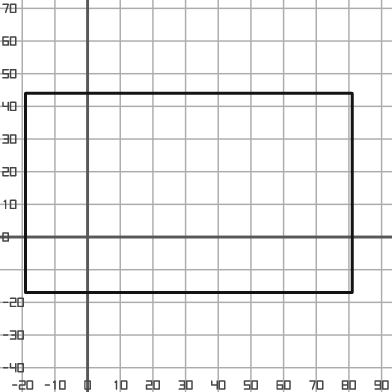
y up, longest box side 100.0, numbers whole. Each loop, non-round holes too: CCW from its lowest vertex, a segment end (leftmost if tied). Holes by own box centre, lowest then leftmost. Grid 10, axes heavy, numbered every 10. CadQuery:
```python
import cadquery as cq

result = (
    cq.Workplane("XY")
    .moveTo(-19.0, -17.0)
    .lineTo(81.0, -17.0)
    .lineTo(81.0, 44.0)
    .lineTo(-19.0, 44.0)
    .close()
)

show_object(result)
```